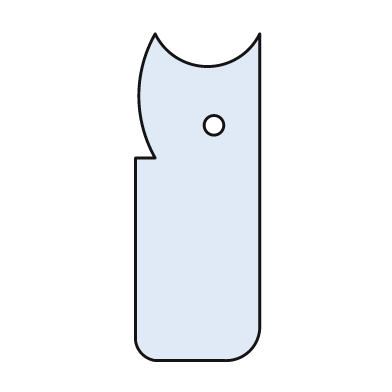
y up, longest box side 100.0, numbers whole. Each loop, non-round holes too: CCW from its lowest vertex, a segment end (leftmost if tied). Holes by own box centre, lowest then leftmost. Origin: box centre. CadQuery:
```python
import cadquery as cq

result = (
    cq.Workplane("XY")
    .moveTo(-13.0, -50.0)
    .lineTo(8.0, -50.0)
    .threePointArc((16.0, -47.0), (19.0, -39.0))
    .lineTo(19.0, 50.0)
    .threePointArc((3.0, 40.0), (-13.0, 50.0))
    .threePointArc((-18.0, 31.0), (-13.0, 12.0))
    .lineTo(-19.0, 12.0)
    .lineTo(-19.0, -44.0)
    .threePointArc((-17.0, -48.0), (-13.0, -50.0))
    .close()
    .moveTo(5.0, 22.0)
    .circle(3.0)
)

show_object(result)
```